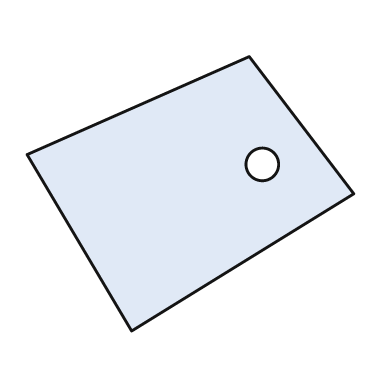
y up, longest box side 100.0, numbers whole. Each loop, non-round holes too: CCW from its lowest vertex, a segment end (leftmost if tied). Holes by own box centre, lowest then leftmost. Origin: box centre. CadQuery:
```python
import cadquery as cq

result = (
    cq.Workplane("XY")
    .moveTo(-18.0, -42.0)
    .lineTo(50.0, 0.0)
    .lineTo(18.0, 42.0)
    .lineTo(-50.0, 12.0)
    .close()
    .moveTo(22.0, 9.0)
    .circle(5.0)
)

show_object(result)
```